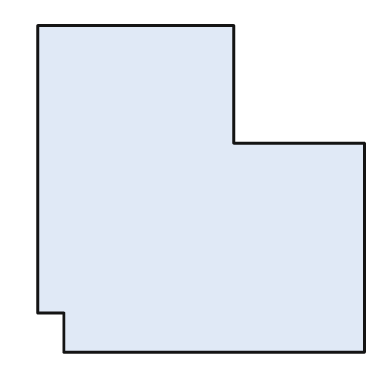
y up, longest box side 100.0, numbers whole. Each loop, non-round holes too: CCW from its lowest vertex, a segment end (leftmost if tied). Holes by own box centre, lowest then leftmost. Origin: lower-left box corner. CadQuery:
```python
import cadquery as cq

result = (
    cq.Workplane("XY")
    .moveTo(8.0, 0.0)
    .lineTo(100.0, 0.0)
    .lineTo(100.0, 64.0)
    .lineTo(60.0, 64.0)
    .lineTo(60.0, 100.0)
    .lineTo(0.0, 100.0)
    .lineTo(0.0, 12.0)
    .lineTo(8.0, 12.0)
    .close()
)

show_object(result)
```